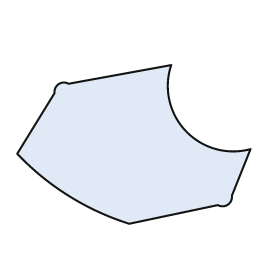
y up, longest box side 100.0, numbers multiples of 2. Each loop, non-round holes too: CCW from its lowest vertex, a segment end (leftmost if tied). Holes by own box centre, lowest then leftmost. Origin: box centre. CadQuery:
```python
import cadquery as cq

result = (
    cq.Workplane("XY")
    .moveTo(-2.0, -34.0)
    .lineTo(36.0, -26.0)
    .threePointArc((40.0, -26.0), (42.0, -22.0))
    .lineTo(50.0, -2.0)
    .threePointArc((22.0, 6.0), (16.0, 34.0))
    .lineTo(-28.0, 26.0)
    .threePointArc((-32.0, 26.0), (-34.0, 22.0))
    .lineTo(-50.0, -4.0)
    .threePointArc((-28.0, -22.0), (-2.0, -34.0))
    .close()
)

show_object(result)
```